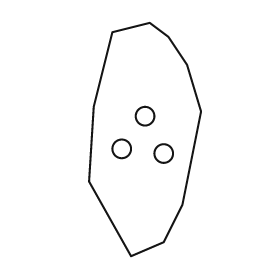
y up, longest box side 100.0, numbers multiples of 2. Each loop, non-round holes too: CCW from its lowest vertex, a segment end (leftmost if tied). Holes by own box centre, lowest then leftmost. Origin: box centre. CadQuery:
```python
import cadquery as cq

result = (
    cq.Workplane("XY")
    .moveTo(-6.0, -50.0)
    .lineTo(8.0, -44.0)
    .lineTo(16.0, -28.0)
    .lineTo(24.0, 12.0)
    .lineTo(18.0, 32.0)
    .lineTo(10.0, 44.0)
    .lineTo(2.0, 50.0)
    .lineTo(-14.0, 46.0)
    .lineTo(-22.0, 14.0)
    .lineTo(-24.0, -18.0)
    .close()
    .moveTo(8.0, -6.0)
    .circle(4.0)
    .moveTo(-10.0, -4.0)
    .circle(4.0)
    .moveTo(0.0, 10.0)
    .circle(4.0)
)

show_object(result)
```